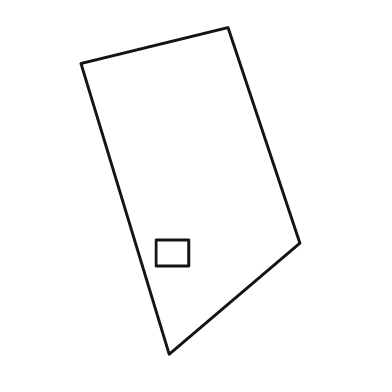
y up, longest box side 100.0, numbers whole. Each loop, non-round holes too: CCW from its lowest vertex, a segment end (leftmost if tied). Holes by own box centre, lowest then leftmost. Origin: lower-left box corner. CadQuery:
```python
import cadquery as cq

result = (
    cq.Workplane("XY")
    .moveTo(27.0, 0.0)
    .lineTo(67.0, 34.0)
    .lineTo(45.0, 100.0)
    .lineTo(0.0, 89.0)
    .close()
    .moveTo(23.0, 27.0)
    .lineTo(33.0, 27.0)
    .lineTo(33.0, 35.0)
    .lineTo(23.0, 35.0)
    .close()
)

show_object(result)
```